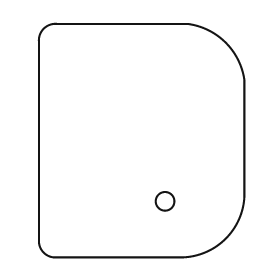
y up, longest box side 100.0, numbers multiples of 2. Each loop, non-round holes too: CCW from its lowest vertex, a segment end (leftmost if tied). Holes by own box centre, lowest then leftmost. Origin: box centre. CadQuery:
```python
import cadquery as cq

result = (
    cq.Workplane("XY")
    .moveTo(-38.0, -50.0)
    .lineTo(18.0, -50.0)
    .threePointArc((36.0, -42.0), (44.0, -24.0))
    .lineTo(44.0, 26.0)
    .threePointArc((36.0, 42.0), (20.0, 50.0))
    .lineTo(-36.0, 50.0)
    .threePointArc((-42.0, 48.0), (-44.0, 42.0))
    .lineTo(-44.0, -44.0)
    .threePointArc((-42.0, -48.0), (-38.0, -50.0))
    .close()
    .moveTo(10.0, -26.0)
    .circle(4.0)
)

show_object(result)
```